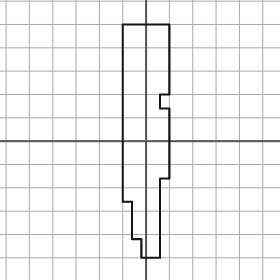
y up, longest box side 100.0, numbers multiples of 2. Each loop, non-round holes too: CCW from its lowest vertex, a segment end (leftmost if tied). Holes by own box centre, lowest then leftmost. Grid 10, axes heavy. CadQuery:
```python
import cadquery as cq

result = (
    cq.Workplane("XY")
    .moveTo(-2.0, -50.0)
    .lineTo(6.0, -50.0)
    .lineTo(6.0, -16.0)
    .lineTo(10.0, -16.0)
    .lineTo(10.0, 14.0)
    .lineTo(6.0, 14.0)
    .lineTo(6.0, 20.0)
    .lineTo(10.0, 20.0)
    .lineTo(10.0, 50.0)
    .lineTo(-10.0, 50.0)
    .lineTo(-10.0, -26.0)
    .lineTo(-6.0, -26.0)
    .lineTo(-6.0, -42.0)
    .lineTo(-2.0, -42.0)
    .close()
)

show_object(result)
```